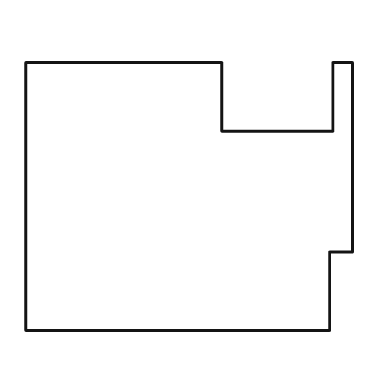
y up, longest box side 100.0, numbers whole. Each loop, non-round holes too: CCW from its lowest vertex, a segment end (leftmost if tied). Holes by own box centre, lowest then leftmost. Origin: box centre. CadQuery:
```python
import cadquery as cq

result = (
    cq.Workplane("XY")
    .moveTo(-50.0, -41.0)
    .lineTo(43.0, -41.0)
    .lineTo(43.0, -17.0)
    .lineTo(50.0, -17.0)
    .lineTo(50.0, 41.0)
    .lineTo(44.0, 41.0)
    .lineTo(44.0, 20.0)
    .lineTo(10.0, 20.0)
    .lineTo(10.0, 41.0)
    .lineTo(-50.0, 41.0)
    .close()
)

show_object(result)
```